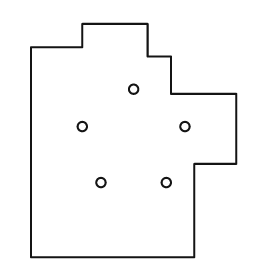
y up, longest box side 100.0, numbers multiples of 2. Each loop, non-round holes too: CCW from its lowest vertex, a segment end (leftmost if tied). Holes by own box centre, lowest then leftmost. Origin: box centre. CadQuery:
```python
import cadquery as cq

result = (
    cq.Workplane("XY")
    .moveTo(-44.0, -50.0)
    .lineTo(26.0, -50.0)
    .lineTo(26.0, -10.0)
    .lineTo(44.0, -10.0)
    .lineTo(44.0, 20.0)
    .lineTo(16.0, 20.0)
    .lineTo(16.0, 36.0)
    .lineTo(6.0, 36.0)
    .lineTo(6.0, 50.0)
    .lineTo(-22.0, 50.0)
    .lineTo(-22.0, 40.0)
    .lineTo(-44.0, 40.0)
    .close()
    .moveTo(-14.0, -18.0)
    .circle(2.0)
    .moveTo(14.0, -18.0)
    .circle(2.0)
    .moveTo(-22.0, 6.0)
    .circle(2.0)
    .moveTo(22.0, 6.0)
    .circle(2.0)
    .moveTo(0.0, 22.0)
    .circle(2.0)
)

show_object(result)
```